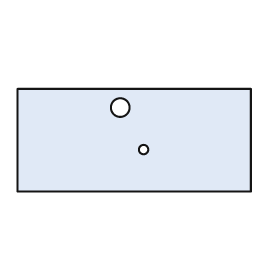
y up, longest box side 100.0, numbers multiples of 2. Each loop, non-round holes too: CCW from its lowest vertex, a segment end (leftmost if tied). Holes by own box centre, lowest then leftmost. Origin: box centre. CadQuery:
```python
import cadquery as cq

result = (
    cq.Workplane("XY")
    .moveTo(-50.0, -22.0)
    .lineTo(50.0, -22.0)
    .lineTo(50.0, 22.0)
    .lineTo(-50.0, 22.0)
    .close()
    .moveTo(4.0, -4.0)
    .circle(2.0)
    .moveTo(-6.0, 14.0)
    .circle(4.0)
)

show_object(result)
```